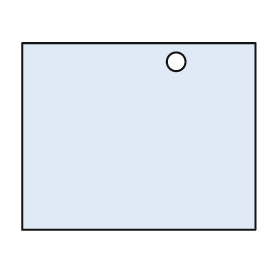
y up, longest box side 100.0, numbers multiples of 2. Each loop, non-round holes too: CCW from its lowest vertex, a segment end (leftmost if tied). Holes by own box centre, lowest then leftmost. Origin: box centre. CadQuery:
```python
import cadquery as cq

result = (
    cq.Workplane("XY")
    .moveTo(-50.0, -40.0)
    .lineTo(50.0, -40.0)
    .lineTo(50.0, 40.0)
    .lineTo(-50.0, 40.0)
    .close()
    .moveTo(16.0, 32.0)
    .circle(4.0)
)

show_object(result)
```